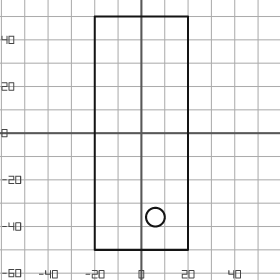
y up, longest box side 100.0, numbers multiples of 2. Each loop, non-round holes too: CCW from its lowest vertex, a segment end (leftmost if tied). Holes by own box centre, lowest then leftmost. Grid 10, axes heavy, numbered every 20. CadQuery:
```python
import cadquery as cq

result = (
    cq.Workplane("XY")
    .moveTo(-20.0, -50.0)
    .lineTo(20.0, -50.0)
    .lineTo(20.0, 50.0)
    .lineTo(-20.0, 50.0)
    .close()
    .moveTo(6.0, -36.0)
    .circle(4.0)
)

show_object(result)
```